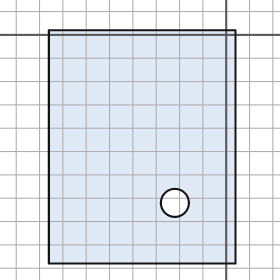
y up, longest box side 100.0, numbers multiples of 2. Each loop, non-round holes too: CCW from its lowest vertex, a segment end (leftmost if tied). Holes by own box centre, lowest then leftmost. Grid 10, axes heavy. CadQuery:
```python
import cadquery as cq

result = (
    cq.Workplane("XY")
    .moveTo(-76.0, -98.0)
    .lineTo(4.0, -98.0)
    .lineTo(4.0, 2.0)
    .lineTo(-76.0, 2.0)
    .close()
    .moveTo(-22.0, -72.0)
    .circle(6.0)
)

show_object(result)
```